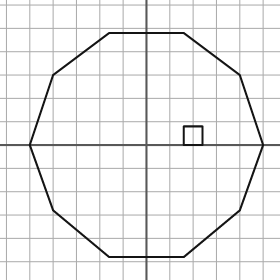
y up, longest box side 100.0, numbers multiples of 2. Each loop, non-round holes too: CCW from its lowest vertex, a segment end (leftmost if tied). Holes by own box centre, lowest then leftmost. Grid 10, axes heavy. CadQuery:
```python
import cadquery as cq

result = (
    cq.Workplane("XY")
    .moveTo(-16.0, -48.0)
    .lineTo(16.0, -48.0)
    .lineTo(40.0, -28.0)
    .lineTo(50.0, 0.0)
    .lineTo(40.0, 30.0)
    .lineTo(16.0, 48.0)
    .lineTo(-16.0, 48.0)
    .lineTo(-40.0, 30.0)
    .lineTo(-50.0, 0.0)
    .lineTo(-40.0, -28.0)
    .close()
    .moveTo(16.0, 0.0)
    .lineTo(24.0, 0.0)
    .lineTo(24.0, 8.0)
    .lineTo(16.0, 8.0)
    .close()
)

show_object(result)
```